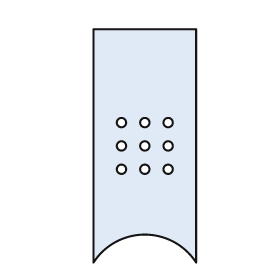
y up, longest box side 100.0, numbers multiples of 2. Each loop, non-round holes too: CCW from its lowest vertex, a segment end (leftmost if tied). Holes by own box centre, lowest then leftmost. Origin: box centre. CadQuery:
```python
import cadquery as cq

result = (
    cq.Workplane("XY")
    .moveTo(-22.0, -50.0)
    .threePointArc((0.0, -38.0), (22.0, -50.0))
    .lineTo(22.0, 50.0)
    .lineTo(-22.0, 50.0)
    .close()
    .moveTo(-10.0, -10.0)
    .circle(2.0)
    .moveTo(0.0, -10.0)
    .circle(2.0)
    .moveTo(10.0, -10.0)
    .circle(2.0)
    .moveTo(-10.0, 0.0)
    .circle(2.0)
    .moveTo(0.0, 0.0)
    .circle(2.0)
    .moveTo(10.0, 0.0)
    .circle(2.0)
    .moveTo(-10.0, 10.0)
    .circle(2.0)
    .moveTo(0.0, 10.0)
    .circle(2.0)
    .moveTo(10.0, 10.0)
    .circle(2.0)
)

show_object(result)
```